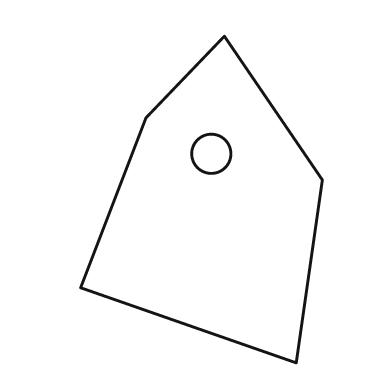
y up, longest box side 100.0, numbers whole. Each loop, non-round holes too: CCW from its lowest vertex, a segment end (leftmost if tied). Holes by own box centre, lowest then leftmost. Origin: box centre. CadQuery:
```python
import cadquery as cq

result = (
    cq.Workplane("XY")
    .moveTo(29.0, -50.0)
    .lineTo(37.0, 6.0)
    .lineTo(7.0, 50.0)
    .lineTo(-17.0, 25.0)
    .lineTo(-37.0, -27.0)
    .close()
    .moveTo(3.0, 14.0)
    .circle(6.0)
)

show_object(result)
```